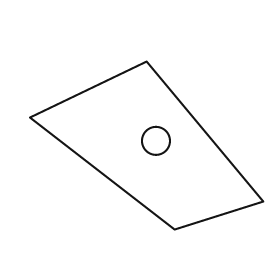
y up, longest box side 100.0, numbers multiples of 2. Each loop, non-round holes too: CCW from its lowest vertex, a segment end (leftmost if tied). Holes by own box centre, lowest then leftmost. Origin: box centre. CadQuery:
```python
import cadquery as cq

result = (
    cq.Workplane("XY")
    .moveTo(12.0, -36.0)
    .lineTo(50.0, -24.0)
    .lineTo(0.0, 36.0)
    .lineTo(-50.0, 12.0)
    .close()
    .moveTo(4.0, 2.0)
    .circle(6.0)
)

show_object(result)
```